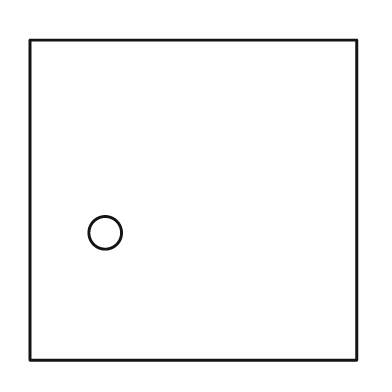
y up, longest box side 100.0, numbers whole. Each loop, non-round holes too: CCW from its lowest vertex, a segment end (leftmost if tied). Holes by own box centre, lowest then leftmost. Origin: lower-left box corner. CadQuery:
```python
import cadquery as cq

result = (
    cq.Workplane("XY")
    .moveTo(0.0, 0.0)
    .lineTo(100.0, 0.0)
    .lineTo(100.0, 98.0)
    .lineTo(0.0, 98.0)
    .close()
    .moveTo(23.0, 39.0)
    .circle(5.0)
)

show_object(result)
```